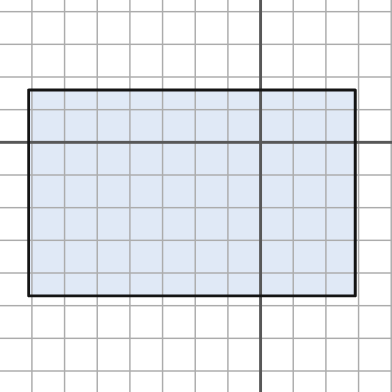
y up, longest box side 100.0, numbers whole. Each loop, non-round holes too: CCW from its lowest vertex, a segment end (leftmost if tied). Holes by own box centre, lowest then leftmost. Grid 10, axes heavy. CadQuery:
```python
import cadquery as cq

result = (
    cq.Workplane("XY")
    .moveTo(-71.0, -47.0)
    .lineTo(29.0, -47.0)
    .lineTo(29.0, 16.0)
    .lineTo(-71.0, 16.0)
    .close()
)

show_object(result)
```